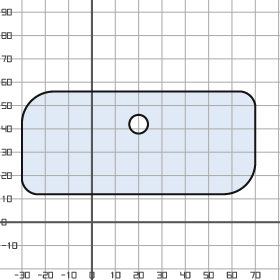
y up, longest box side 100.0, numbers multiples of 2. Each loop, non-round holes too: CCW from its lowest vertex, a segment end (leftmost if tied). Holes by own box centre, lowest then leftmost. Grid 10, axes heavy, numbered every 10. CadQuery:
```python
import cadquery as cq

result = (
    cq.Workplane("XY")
    .moveTo(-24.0, 12.0)
    .lineTo(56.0, 12.0)
    .threePointArc((66.0, 16.0), (70.0, 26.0))
    .lineTo(70.0, 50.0)
    .threePointArc((68.0, 54.0), (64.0, 56.0))
    .lineTo(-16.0, 56.0)
    .threePointArc((-26.0, 52.0), (-30.0, 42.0))
    .lineTo(-30.0, 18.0)
    .threePointArc((-28.0, 14.0), (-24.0, 12.0))
    .close()
    .moveTo(20.0, 42.0)
    .circle(4.0)
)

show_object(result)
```